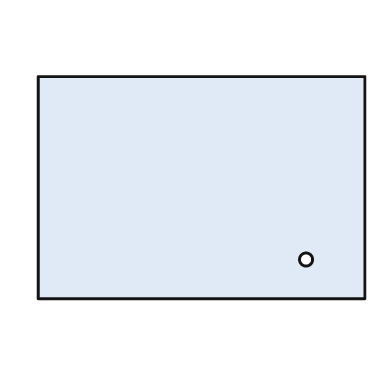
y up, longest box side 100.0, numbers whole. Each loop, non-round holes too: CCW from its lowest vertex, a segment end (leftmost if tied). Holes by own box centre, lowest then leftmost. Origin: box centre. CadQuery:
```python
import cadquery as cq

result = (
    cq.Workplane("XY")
    .moveTo(-50.0, -34.0)
    .lineTo(50.0, -34.0)
    .lineTo(50.0, 34.0)
    .lineTo(-50.0, 34.0)
    .close()
    .moveTo(32.0, -22.0)
    .circle(2.0)
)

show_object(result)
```